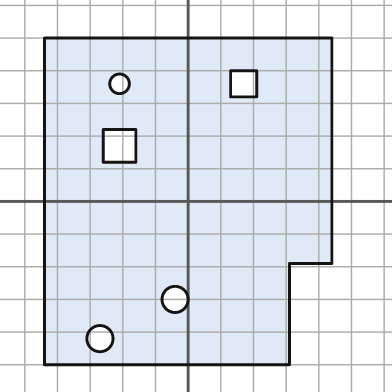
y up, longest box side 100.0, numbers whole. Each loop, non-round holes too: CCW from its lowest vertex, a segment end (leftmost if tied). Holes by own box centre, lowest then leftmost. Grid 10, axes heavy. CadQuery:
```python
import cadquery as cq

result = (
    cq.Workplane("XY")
    .moveTo(-44.0, -50.0)
    .lineTo(31.0, -50.0)
    .lineTo(31.0, -19.0)
    .lineTo(44.0, -19.0)
    .lineTo(44.0, 50.0)
    .lineTo(-44.0, 50.0)
    .close()
    .moveTo(-27.0, -42.0)
    .circle(4.0)
    .moveTo(-4.0, -30.0)
    .circle(4.0)
    .moveTo(-26.0, 12.0)
    .lineTo(-16.0, 12.0)
    .lineTo(-16.0, 22.0)
    .lineTo(-26.0, 22.0)
    .close()
    .moveTo(-21.0, 36.0)
    .circle(3.0)
    .moveTo(13.0, 32.0)
    .lineTo(21.0, 32.0)
    .lineTo(21.0, 40.0)
    .lineTo(13.0, 40.0)
    .close()
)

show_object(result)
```